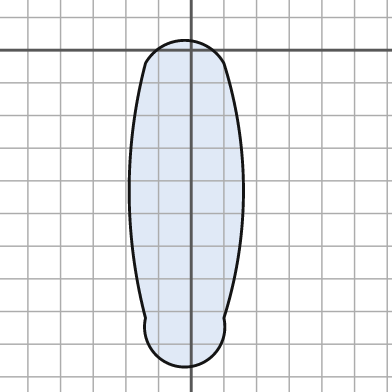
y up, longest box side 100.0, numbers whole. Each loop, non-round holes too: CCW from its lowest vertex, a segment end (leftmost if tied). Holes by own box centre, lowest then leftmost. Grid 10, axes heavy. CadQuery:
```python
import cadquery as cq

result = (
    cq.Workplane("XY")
    .moveTo(-14.0, -82.0)
    .threePointArc((-2.0, -97.0), (10.0, -82.0))
    .threePointArc((16.0, -43.0), (10.0, -4.0))
    .threePointArc((-2.0, 3.0), (-14.0, -4.0))
    .threePointArc((-19.0, -43.0), (-14.0, -82.0))
    .close()
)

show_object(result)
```